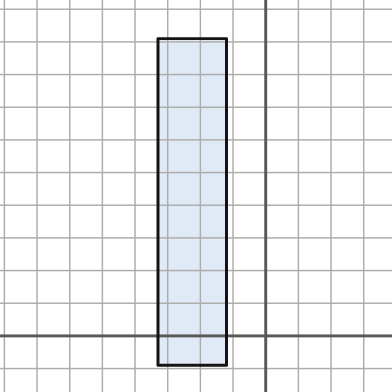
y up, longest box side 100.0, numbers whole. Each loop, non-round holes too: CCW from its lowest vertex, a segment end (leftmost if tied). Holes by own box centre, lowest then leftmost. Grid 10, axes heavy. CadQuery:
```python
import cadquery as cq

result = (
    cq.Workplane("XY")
    .moveTo(-33.0, -9.0)
    .lineTo(-12.0, -9.0)
    .lineTo(-12.0, 91.0)
    .lineTo(-33.0, 91.0)
    .close()
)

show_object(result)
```